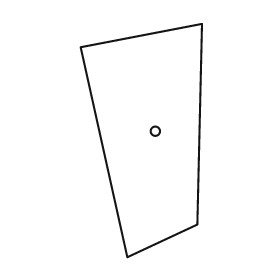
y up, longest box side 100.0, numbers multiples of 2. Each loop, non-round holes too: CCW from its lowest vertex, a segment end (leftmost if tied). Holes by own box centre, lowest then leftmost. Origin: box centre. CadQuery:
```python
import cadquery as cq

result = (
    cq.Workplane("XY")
    .moveTo(-6.0, -50.0)
    .lineTo(24.0, -36.0)
    .lineTo(26.0, 50.0)
    .lineTo(-26.0, 40.0)
    .close()
    .moveTo(6.0, 4.0)
    .circle(2.0)
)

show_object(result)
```